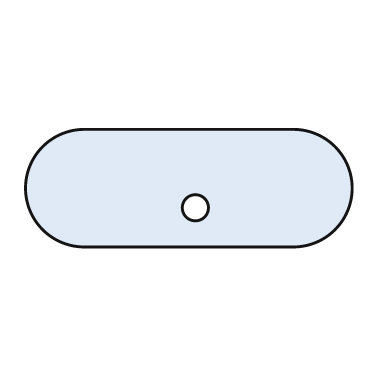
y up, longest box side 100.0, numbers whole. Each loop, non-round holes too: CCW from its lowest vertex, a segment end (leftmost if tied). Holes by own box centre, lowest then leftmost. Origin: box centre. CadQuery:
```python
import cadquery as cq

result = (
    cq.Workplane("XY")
    .moveTo(-32.0, -18.0)
    .lineTo(32.0, -18.0)
    .threePointArc((50.0, 0.0), (32.0, 18.0))
    .lineTo(-32.0, 18.0)
    .threePointArc((-50.0, 0.0), (-32.0, -18.0))
    .close()
    .moveTo(2.0, -6.0)
    .circle(4.0)
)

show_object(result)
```